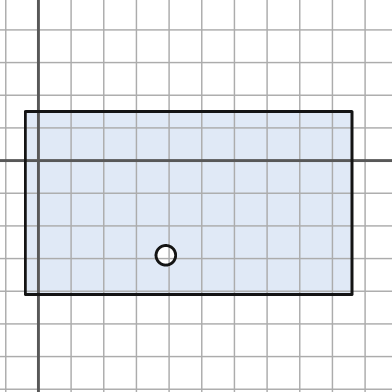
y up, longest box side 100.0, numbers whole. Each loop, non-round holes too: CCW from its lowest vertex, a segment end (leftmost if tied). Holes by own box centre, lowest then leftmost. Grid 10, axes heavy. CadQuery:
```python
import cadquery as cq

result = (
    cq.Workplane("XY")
    .moveTo(-4.0, -41.0)
    .lineTo(96.0, -41.0)
    .lineTo(96.0, 15.0)
    .lineTo(-4.0, 15.0)
    .close()
    .moveTo(39.0, -29.0)
    .circle(3.0)
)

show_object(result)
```